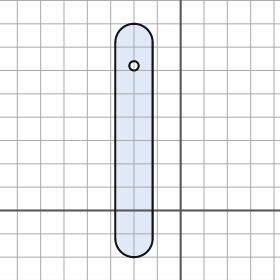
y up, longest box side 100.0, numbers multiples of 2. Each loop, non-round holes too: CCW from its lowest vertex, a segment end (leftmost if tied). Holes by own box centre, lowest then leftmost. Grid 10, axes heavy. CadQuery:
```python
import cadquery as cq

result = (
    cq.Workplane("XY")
    .moveTo(-28.0, -12.0)
    .threePointArc((-20.0, -20.0), (-12.0, -12.0))
    .lineTo(-12.0, 72.0)
    .threePointArc((-20.0, 80.0), (-28.0, 72.0))
    .close()
    .moveTo(-20.0, 62.0)
    .circle(2.0)
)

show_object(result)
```